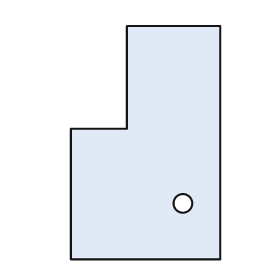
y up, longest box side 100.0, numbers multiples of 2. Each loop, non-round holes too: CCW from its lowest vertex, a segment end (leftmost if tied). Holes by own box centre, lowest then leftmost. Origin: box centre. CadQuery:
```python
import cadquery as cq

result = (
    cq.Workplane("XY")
    .moveTo(-32.0, -50.0)
    .lineTo(32.0, -50.0)
    .lineTo(32.0, 50.0)
    .lineTo(-8.0, 50.0)
    .lineTo(-8.0, 6.0)
    .lineTo(-32.0, 6.0)
    .close()
    .moveTo(16.0, -26.0)
    .circle(4.0)
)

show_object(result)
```